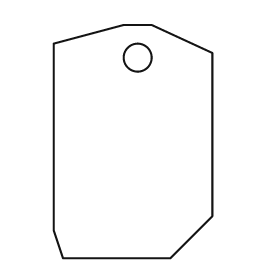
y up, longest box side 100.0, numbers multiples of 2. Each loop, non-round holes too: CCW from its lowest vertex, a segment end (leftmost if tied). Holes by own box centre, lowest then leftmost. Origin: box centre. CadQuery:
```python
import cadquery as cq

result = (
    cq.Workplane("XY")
    .moveTo(-30.0, -50.0)
    .lineTo(16.0, -50.0)
    .lineTo(34.0, -32.0)
    .lineTo(34.0, 38.0)
    .lineTo(8.0, 50.0)
    .lineTo(-4.0, 50.0)
    .lineTo(-34.0, 42.0)
    .lineTo(-34.0, -38.0)
    .close()
    .moveTo(2.0, 36.0)
    .circle(6.0)
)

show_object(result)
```